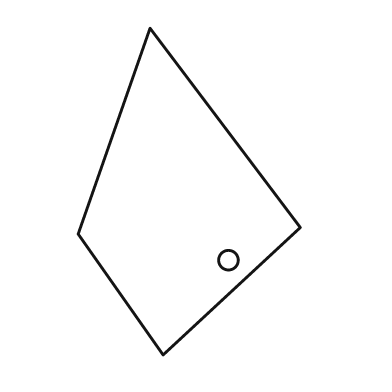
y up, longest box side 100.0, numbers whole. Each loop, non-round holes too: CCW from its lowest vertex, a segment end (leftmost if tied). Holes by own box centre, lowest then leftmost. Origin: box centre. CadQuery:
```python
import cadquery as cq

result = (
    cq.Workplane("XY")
    .moveTo(-8.0, -50.0)
    .lineTo(34.0, -11.0)
    .lineTo(-12.0, 50.0)
    .lineTo(-34.0, -13.0)
    .close()
    .moveTo(12.0, -21.0)
    .circle(3.0)
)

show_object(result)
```